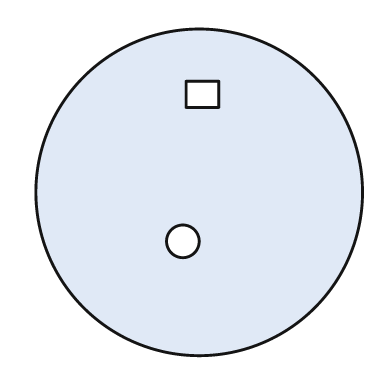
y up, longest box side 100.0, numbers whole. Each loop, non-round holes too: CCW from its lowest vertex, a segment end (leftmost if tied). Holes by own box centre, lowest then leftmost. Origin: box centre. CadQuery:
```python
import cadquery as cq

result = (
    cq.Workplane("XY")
    .moveTo(0.0, 0.0)
    .circle(50.0)
    .moveTo(-5.0, -15.0)
    .circle(5.0)
    .moveTo(-4.0, 26.0)
    .lineTo(6.0, 26.0)
    .lineTo(6.0, 34.0)
    .lineTo(-4.0, 34.0)
    .close()
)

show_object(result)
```